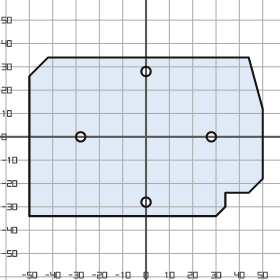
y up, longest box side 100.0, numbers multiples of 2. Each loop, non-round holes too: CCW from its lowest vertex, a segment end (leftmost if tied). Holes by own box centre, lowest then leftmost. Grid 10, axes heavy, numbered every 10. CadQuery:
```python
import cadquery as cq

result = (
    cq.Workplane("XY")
    .moveTo(-50.0, -34.0)
    .lineTo(30.0, -34.0)
    .lineTo(34.0, -30.0)
    .lineTo(34.0, -24.0)
    .lineTo(44.0, -24.0)
    .lineTo(50.0, -18.0)
    .lineTo(50.0, 12.0)
    .lineTo(44.0, 34.0)
    .lineTo(-42.0, 34.0)
    .lineTo(-50.0, 26.0)
    .close()
    .moveTo(0.0, -28.0)
    .circle(2.0)
    .moveTo(-28.0, 0.0)
    .circle(2.0)
    .moveTo(28.0, 0.0)
    .circle(2.0)
    .moveTo(0.0, 28.0)
    .circle(2.0)
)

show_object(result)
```